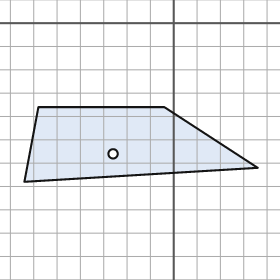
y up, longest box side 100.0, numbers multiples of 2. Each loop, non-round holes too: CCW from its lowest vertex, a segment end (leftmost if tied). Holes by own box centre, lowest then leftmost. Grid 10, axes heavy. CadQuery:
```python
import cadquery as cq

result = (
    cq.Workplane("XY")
    .moveTo(-64.0, -68.0)
    .lineTo(36.0, -62.0)
    .lineTo(-4.0, -36.0)
    .lineTo(-58.0, -36.0)
    .close()
    .moveTo(-26.0, -56.0)
    .circle(2.0)
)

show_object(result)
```